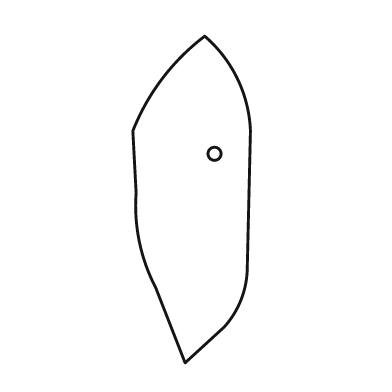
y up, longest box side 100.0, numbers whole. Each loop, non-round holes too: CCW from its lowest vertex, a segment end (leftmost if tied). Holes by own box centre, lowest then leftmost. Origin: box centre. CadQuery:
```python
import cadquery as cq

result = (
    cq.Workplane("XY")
    .moveTo(-2.0, -50.0)
    .lineTo(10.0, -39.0)
    .threePointArc((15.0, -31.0), (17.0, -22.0))
    .lineTo(18.0, 21.0)
    .threePointArc((14.0, 37.0), (4.0, 50.0))
    .threePointArc((-9.0, 37.0), (-18.0, 21.0))
    .lineTo(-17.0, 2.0)
    .threePointArc((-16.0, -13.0), (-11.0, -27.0))
    .close()
    .moveTo(7.0, 14.0)
    .circle(2.0)
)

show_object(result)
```